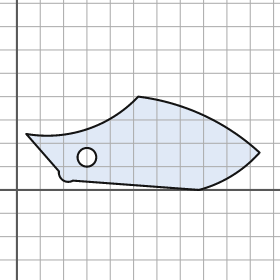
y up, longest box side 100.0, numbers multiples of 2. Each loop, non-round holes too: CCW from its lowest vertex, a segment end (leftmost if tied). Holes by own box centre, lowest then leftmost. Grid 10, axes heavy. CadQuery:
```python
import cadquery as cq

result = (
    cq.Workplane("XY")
    .moveTo(78.0, 0.0)
    .threePointArc((92.0, 6.0), (104.0, 16.0))
    .threePointArc((80.0, 32.0), (52.0, 40.0))
    .threePointArc((30.0, 26.0), (4.0, 24.0))
    .lineTo(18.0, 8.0)
    .threePointArc((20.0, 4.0), (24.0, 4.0))
    .close()
    .moveTo(30.0, 14.0)
    .circle(4.0)
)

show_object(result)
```